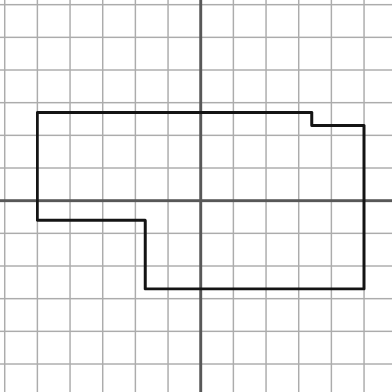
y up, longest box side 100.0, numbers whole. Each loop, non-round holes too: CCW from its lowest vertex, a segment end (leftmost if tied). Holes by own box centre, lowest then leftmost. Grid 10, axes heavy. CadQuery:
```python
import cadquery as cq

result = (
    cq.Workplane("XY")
    .moveTo(-17.0, -27.0)
    .lineTo(50.0, -27.0)
    .lineTo(50.0, 23.0)
    .lineTo(34.0, 23.0)
    .lineTo(34.0, 27.0)
    .lineTo(-50.0, 27.0)
    .lineTo(-50.0, -6.0)
    .lineTo(-17.0, -6.0)
    .close()
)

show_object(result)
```